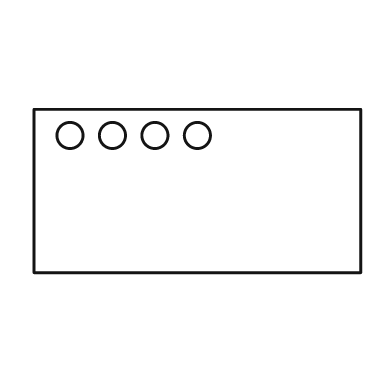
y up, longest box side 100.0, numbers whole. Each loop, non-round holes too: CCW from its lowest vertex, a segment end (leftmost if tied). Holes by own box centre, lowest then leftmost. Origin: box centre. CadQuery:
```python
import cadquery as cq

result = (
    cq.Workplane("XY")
    .moveTo(-50.0, -25.0)
    .lineTo(50.0, -25.0)
    .lineTo(50.0, 25.0)
    .lineTo(-50.0, 25.0)
    .close()
    .moveTo(-39.0, 17.0)
    .circle(4.0)
    .moveTo(-26.0, 17.0)
    .circle(4.0)
    .moveTo(-13.0, 17.0)
    .circle(4.0)
    .moveTo(0.0, 17.0)
    .circle(4.0)
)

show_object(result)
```